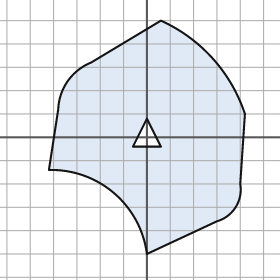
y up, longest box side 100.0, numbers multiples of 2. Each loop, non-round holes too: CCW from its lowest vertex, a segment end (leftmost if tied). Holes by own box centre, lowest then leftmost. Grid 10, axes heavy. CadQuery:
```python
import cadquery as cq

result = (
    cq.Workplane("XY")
    .moveTo(0.0, -50.0)
    .lineTo(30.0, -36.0)
    .threePointArc((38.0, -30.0), (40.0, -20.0))
    .lineTo(42.0, 10.0)
    .threePointArc((28.0, 34.0), (6.0, 50.0))
    .lineTo(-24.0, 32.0)
    .threePointArc((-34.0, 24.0), (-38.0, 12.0))
    .lineTo(-42.0, -14.0)
    .threePointArc((-14.0, -24.0), (0.0, -50.0))
    .close()
    .moveTo(-6.0, -4.0)
    .lineTo(6.0, -4.0)
    .lineTo(0.0, 8.0)
    .close()
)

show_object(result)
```